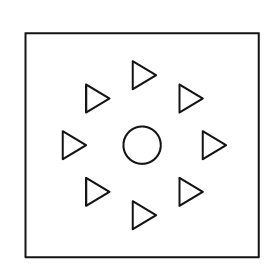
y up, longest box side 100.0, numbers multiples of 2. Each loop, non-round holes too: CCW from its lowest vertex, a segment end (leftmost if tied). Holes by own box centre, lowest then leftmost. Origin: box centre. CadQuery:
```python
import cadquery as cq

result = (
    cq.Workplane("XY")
    .moveTo(-50.0, -48.0)
    .lineTo(50.0, -48.0)
    .lineTo(50.0, 48.0)
    .lineTo(-50.0, 48.0)
    .close()
    .moveTo(-4.0, -36.0)
    .lineTo(6.0, -30.0)
    .lineTo(-4.0, -24.0)
    .close()
    .moveTo(-24.0, -26.0)
    .lineTo(-14.0, -20.0)
    .lineTo(-24.0, -14.0)
    .close()
    .moveTo(16.0, -26.0)
    .lineTo(26.0, -20.0)
    .lineTo(16.0, -14.0)
    .close()
    .moveTo(-34.0, -6.0)
    .lineTo(-24.0, 0.0)
    .lineTo(-34.0, 6.0)
    .close()
    .moveTo(0.0, 0.0)
    .circle(8.0)
    .moveTo(26.0, -6.0)
    .lineTo(36.0, 0.0)
    .lineTo(26.0, 6.0)
    .close()
    .moveTo(-24.0, 14.0)
    .lineTo(-14.0, 20.0)
    .lineTo(-24.0, 26.0)
    .close()
    .moveTo(16.0, 14.0)
    .lineTo(26.0, 20.0)
    .lineTo(16.0, 26.0)
    .close()
    .moveTo(-4.0, 24.0)
    .lineTo(6.0, 30.0)
    .lineTo(-4.0, 36.0)
    .close()
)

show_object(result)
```